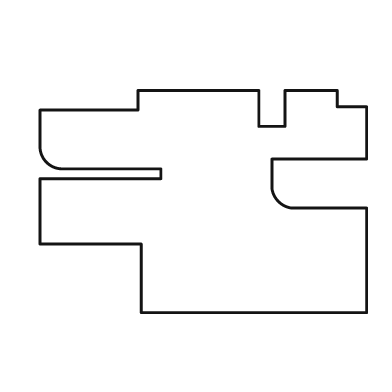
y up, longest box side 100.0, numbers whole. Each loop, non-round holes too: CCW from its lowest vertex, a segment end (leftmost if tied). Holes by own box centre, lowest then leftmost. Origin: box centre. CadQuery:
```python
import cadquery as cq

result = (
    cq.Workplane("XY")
    .moveTo(-19.0, -34.0)
    .lineTo(50.0, -34.0)
    .lineTo(50.0, -2.0)
    .lineTo(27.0, -2.0)
    .threePointArc((23.0, 0.0), (21.0, 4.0))
    .lineTo(21.0, 13.0)
    .lineTo(50.0, 13.0)
    .lineTo(50.0, 29.0)
    .lineTo(41.0, 29.0)
    .lineTo(41.0, 34.0)
    .lineTo(25.0, 34.0)
    .lineTo(25.0, 23.0)
    .lineTo(17.0, 23.0)
    .lineTo(17.0, 34.0)
    .lineTo(-20.0, 34.0)
    .lineTo(-20.0, 28.0)
    .lineTo(-50.0, 28.0)
    .lineTo(-50.0, 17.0)
    .threePointArc((-48.0, 12.0), (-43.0, 10.0))
    .lineTo(-13.0, 10.0)
    .lineTo(-13.0, 7.0)
    .lineTo(-50.0, 7.0)
    .lineTo(-50.0, -13.0)
    .lineTo(-19.0, -13.0)
    .close()
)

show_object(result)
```